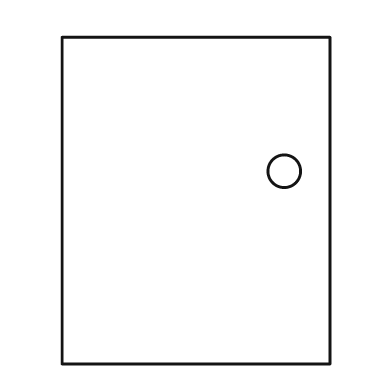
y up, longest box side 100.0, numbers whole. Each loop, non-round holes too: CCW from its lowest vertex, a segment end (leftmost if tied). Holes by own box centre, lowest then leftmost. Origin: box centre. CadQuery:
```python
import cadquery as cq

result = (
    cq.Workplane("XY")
    .moveTo(-41.0, -50.0)
    .lineTo(41.0, -50.0)
    .lineTo(41.0, 50.0)
    .lineTo(-41.0, 50.0)
    .close()
    .moveTo(27.0, 9.0)
    .circle(5.0)
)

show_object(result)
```